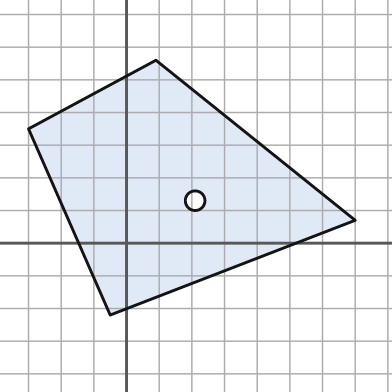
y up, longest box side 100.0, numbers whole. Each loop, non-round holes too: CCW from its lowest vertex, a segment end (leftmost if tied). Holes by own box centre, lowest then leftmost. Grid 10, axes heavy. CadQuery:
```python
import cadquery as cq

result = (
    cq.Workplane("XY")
    .moveTo(-5.0, -22.0)
    .lineTo(70.0, 7.0)
    .lineTo(9.0, 56.0)
    .lineTo(-30.0, 35.0)
    .close()
    .moveTo(21.0, 13.0)
    .circle(3.0)
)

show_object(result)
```